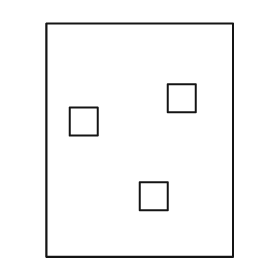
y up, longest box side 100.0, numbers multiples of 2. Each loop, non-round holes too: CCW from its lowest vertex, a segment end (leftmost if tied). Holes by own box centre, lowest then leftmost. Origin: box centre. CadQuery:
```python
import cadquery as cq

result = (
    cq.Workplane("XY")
    .moveTo(-40.0, -50.0)
    .lineTo(40.0, -50.0)
    .lineTo(40.0, 50.0)
    .lineTo(-40.0, 50.0)
    .close()
    .moveTo(0.0, -30.0)
    .lineTo(12.0, -30.0)
    .lineTo(12.0, -18.0)
    .lineTo(0.0, -18.0)
    .close()
    .moveTo(-30.0, 2.0)
    .lineTo(-18.0, 2.0)
    .lineTo(-18.0, 14.0)
    .lineTo(-30.0, 14.0)
    .close()
    .moveTo(12.0, 12.0)
    .lineTo(24.0, 12.0)
    .lineTo(24.0, 24.0)
    .lineTo(12.0, 24.0)
    .close()
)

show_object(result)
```